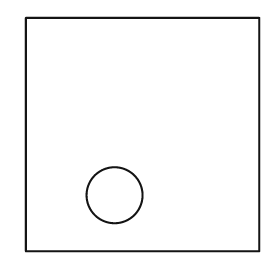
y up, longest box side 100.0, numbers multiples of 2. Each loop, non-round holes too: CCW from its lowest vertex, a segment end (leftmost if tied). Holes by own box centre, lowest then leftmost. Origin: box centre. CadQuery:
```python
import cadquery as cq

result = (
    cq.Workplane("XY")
    .moveTo(-50.0, -50.0)
    .lineTo(50.0, -50.0)
    .lineTo(50.0, 50.0)
    .lineTo(-50.0, 50.0)
    .close()
    .moveTo(-12.0, -26.0)
    .circle(12.0)
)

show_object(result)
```